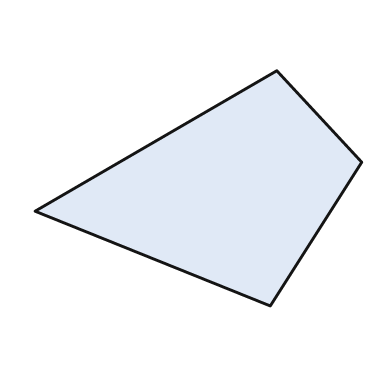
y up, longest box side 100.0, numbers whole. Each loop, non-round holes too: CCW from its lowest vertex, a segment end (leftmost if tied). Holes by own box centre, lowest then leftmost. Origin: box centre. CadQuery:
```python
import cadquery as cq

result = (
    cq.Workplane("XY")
    .moveTo(22.0, -36.0)
    .lineTo(50.0, 8.0)
    .lineTo(24.0, 36.0)
    .lineTo(-50.0, -7.0)
    .close()
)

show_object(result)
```